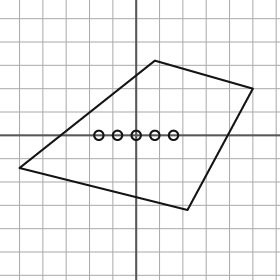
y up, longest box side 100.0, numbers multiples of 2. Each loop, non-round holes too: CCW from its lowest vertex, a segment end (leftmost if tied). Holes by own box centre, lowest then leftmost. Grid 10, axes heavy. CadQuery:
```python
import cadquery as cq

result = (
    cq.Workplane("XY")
    .moveTo(22.0, -32.0)
    .lineTo(50.0, 20.0)
    .lineTo(8.0, 32.0)
    .lineTo(-50.0, -14.0)
    .close()
    .moveTo(-16.0, 0.0)
    .circle(2.0)
    .moveTo(-8.0, 0.0)
    .circle(2.0)
    .moveTo(0.0, 0.0)
    .circle(2.0)
    .moveTo(8.0, 0.0)
    .circle(2.0)
    .moveTo(16.0, 0.0)
    .circle(2.0)
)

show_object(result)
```